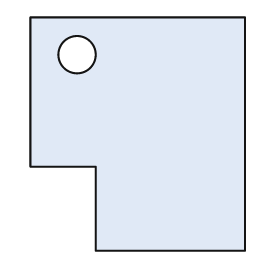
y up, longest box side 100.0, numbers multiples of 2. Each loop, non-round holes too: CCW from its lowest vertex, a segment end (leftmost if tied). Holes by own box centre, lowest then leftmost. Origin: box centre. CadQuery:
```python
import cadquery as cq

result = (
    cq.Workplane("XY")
    .moveTo(-18.0, -50.0)
    .lineTo(46.0, -50.0)
    .lineTo(46.0, 50.0)
    .lineTo(-46.0, 50.0)
    .lineTo(-46.0, -14.0)
    .lineTo(-18.0, -14.0)
    .close()
    .moveTo(-26.0, 34.0)
    .circle(8.0)
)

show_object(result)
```